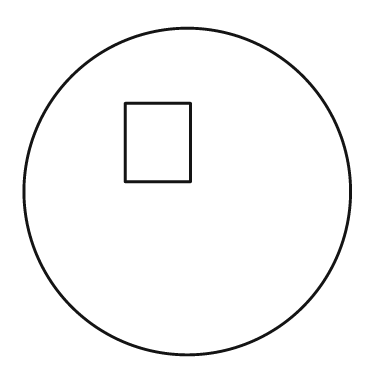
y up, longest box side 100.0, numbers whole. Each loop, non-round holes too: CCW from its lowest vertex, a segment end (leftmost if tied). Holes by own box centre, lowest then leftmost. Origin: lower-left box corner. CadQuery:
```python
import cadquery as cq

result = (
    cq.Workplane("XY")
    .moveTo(50.0, 50.0)
    .circle(50.0)
    .moveTo(31.0, 53.0)
    .lineTo(51.0, 53.0)
    .lineTo(51.0, 77.0)
    .lineTo(31.0, 77.0)
    .close()
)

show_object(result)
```